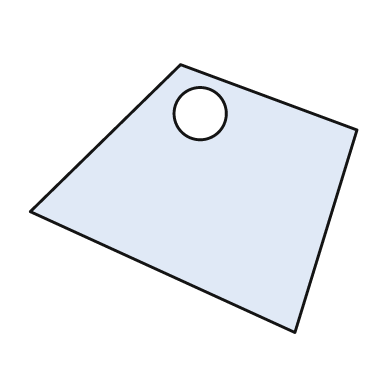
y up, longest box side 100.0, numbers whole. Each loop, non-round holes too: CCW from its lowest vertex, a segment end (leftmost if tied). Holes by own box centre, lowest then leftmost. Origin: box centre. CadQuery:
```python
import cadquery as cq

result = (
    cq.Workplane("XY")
    .moveTo(31.0, -41.0)
    .lineTo(50.0, 21.0)
    .lineTo(-4.0, 41.0)
    .lineTo(-50.0, -4.0)
    .close()
    .moveTo(2.0, 26.0)
    .circle(8.0)
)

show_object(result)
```